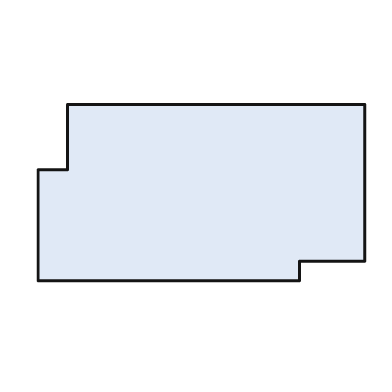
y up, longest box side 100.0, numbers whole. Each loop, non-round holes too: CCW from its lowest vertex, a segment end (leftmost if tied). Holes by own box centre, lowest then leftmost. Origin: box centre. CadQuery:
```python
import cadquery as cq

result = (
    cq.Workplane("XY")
    .moveTo(-50.0, -27.0)
    .lineTo(30.0, -27.0)
    .lineTo(30.0, -21.0)
    .lineTo(50.0, -21.0)
    .lineTo(50.0, 27.0)
    .lineTo(-41.0, 27.0)
    .lineTo(-41.0, 7.0)
    .lineTo(-50.0, 7.0)
    .close()
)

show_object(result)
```